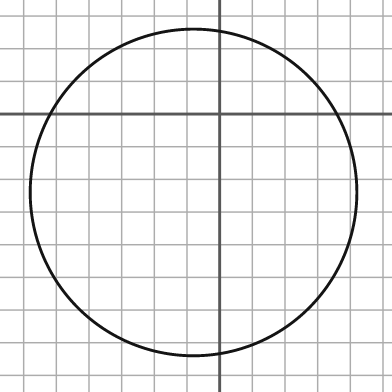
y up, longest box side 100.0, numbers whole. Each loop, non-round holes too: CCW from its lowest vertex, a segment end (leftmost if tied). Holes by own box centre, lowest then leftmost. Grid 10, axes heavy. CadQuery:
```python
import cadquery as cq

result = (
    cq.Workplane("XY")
    .moveTo(-8.0, -24.0)
    .circle(50.0)
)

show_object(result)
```